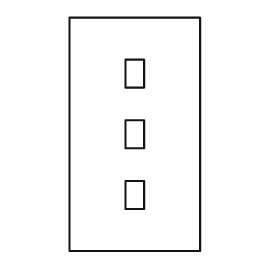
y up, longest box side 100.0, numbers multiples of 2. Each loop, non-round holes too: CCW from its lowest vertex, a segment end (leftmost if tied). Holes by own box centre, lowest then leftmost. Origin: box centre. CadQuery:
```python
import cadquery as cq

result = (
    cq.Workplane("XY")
    .moveTo(-28.0, -50.0)
    .lineTo(28.0, -50.0)
    .lineTo(28.0, 50.0)
    .lineTo(-28.0, 50.0)
    .close()
    .moveTo(-4.0, -32.0)
    .lineTo(4.0, -32.0)
    .lineTo(4.0, -20.0)
    .lineTo(-4.0, -20.0)
    .close()
    .moveTo(-4.0, -6.0)
    .lineTo(4.0, -6.0)
    .lineTo(4.0, 6.0)
    .lineTo(-4.0, 6.0)
    .close()
    .moveTo(-4.0, 20.0)
    .lineTo(4.0, 20.0)
    .lineTo(4.0, 32.0)
    .lineTo(-4.0, 32.0)
    .close()
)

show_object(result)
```